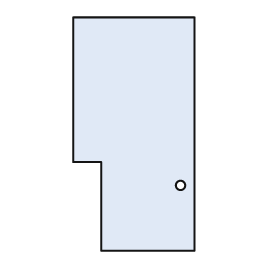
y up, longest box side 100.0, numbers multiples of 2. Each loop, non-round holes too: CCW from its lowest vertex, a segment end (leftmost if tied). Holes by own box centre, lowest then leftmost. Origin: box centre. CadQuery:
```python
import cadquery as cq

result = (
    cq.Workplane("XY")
    .moveTo(-14.0, -50.0)
    .lineTo(26.0, -50.0)
    .lineTo(26.0, 50.0)
    .lineTo(-26.0, 50.0)
    .lineTo(-26.0, -12.0)
    .lineTo(-14.0, -12.0)
    .close()
    .moveTo(20.0, -22.0)
    .circle(2.0)
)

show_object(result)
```